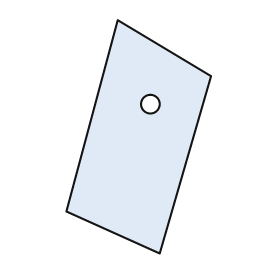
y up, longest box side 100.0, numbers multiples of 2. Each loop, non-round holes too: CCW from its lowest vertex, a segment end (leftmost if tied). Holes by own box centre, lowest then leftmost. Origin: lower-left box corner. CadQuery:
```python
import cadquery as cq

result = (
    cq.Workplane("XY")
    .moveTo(40.0, 0.0)
    .lineTo(62.0, 76.0)
    .lineTo(22.0, 100.0)
    .lineTo(0.0, 18.0)
    .close()
    .moveTo(36.0, 64.0)
    .circle(4.0)
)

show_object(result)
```